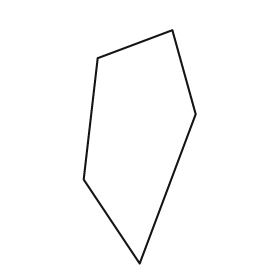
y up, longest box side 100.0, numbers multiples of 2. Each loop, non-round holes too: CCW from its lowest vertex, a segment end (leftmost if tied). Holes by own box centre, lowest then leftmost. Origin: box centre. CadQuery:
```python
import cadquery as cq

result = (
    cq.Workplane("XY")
    .moveTo(0.0, -50.0)
    .lineTo(24.0, 14.0)
    .lineTo(14.0, 50.0)
    .lineTo(-18.0, 38.0)
    .lineTo(-24.0, -14.0)
    .close()
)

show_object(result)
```